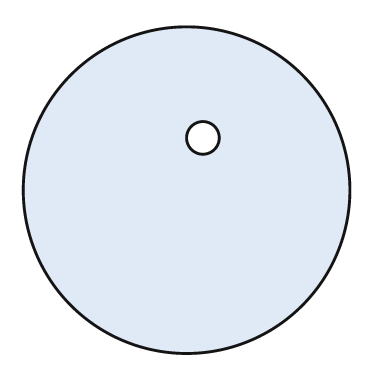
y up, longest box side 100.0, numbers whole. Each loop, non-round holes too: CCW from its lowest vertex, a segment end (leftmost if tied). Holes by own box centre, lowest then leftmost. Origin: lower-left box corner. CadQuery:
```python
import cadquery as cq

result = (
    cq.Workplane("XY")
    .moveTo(50.0, 50.0)
    .circle(50.0)
    .moveTo(55.0, 66.0)
    .circle(5.0)
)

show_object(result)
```